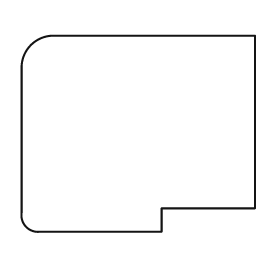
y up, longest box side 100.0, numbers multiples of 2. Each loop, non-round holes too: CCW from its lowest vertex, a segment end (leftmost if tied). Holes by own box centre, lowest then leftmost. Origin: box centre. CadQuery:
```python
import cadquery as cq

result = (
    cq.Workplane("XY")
    .moveTo(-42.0, -42.0)
    .lineTo(10.0, -42.0)
    .lineTo(10.0, -32.0)
    .lineTo(50.0, -32.0)
    .lineTo(50.0, 42.0)
    .lineTo(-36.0, 42.0)
    .threePointArc((-46.0, 38.0), (-50.0, 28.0))
    .lineTo(-50.0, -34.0)
    .threePointArc((-48.0, -40.0), (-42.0, -42.0))
    .close()
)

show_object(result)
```